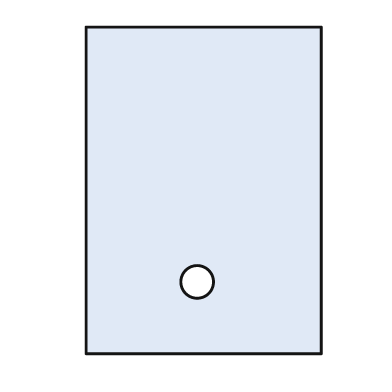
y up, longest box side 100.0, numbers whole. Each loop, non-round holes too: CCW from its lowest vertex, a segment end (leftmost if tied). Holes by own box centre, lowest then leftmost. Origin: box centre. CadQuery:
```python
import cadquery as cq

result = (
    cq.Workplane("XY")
    .moveTo(-36.0, -50.0)
    .lineTo(36.0, -50.0)
    .lineTo(36.0, 50.0)
    .lineTo(-36.0, 50.0)
    .close()
    .moveTo(-2.0, -28.0)
    .circle(5.0)
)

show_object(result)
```